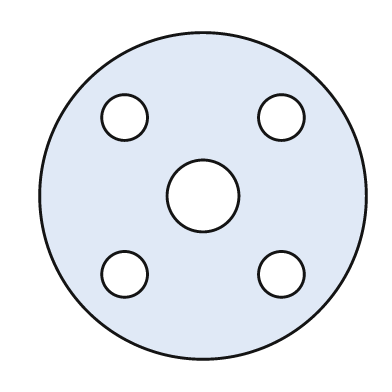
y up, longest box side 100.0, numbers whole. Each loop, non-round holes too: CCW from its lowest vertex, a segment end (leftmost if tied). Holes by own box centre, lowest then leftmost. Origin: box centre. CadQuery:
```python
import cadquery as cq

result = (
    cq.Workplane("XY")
    .moveTo(0.0, 0.0)
    .circle(50.0)
    .moveTo(-24.0, -24.0)
    .circle(7.0)
    .moveTo(24.0, -24.0)
    .circle(7.0)
    .moveTo(0.0, 0.0)
    .circle(11.0)
    .moveTo(-24.0, 24.0)
    .circle(7.0)
    .moveTo(24.0, 24.0)
    .circle(7.0)
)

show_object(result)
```